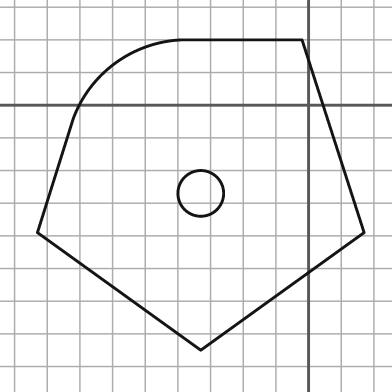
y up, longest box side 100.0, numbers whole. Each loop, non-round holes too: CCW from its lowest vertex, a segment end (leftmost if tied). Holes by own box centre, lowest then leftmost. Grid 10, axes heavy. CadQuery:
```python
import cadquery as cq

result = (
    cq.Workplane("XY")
    .moveTo(-33.0, -75.0)
    .lineTo(17.0, -39.0)
    .lineTo(-2.0, 20.0)
    .lineTo(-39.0, 20.0)
    .threePointArc((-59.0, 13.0), (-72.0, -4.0))
    .lineTo(-83.0, -39.0)
    .close()
    .moveTo(-33.0, -27.0)
    .circle(7.0)
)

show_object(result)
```